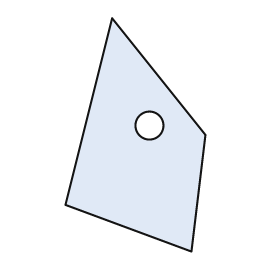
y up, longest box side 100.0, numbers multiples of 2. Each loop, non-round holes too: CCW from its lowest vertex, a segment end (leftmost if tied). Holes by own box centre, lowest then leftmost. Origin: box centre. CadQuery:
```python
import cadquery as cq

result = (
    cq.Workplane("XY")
    .moveTo(24.0, -50.0)
    .lineTo(30.0, 0.0)
    .lineTo(-10.0, 50.0)
    .lineTo(-30.0, -30.0)
    .close()
    .moveTo(6.0, 4.0)
    .circle(6.0)
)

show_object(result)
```